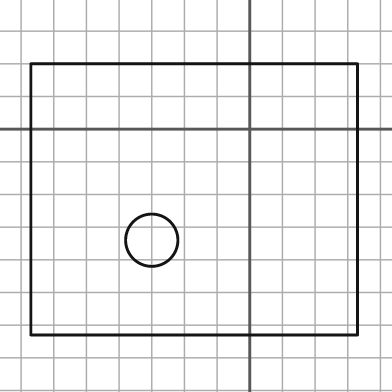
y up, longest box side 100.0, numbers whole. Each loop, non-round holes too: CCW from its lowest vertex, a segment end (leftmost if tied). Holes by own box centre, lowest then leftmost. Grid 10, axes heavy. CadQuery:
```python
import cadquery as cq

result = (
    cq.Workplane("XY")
    .moveTo(-67.0, -63.0)
    .lineTo(33.0, -63.0)
    .lineTo(33.0, 20.0)
    .lineTo(-67.0, 20.0)
    .close()
    .moveTo(-30.0, -34.0)
    .circle(8.0)
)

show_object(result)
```